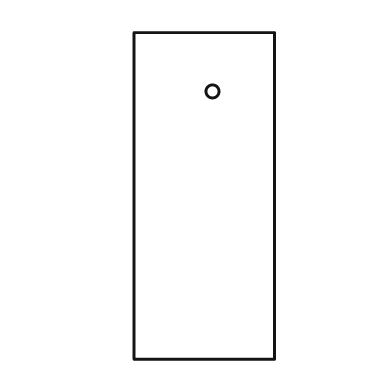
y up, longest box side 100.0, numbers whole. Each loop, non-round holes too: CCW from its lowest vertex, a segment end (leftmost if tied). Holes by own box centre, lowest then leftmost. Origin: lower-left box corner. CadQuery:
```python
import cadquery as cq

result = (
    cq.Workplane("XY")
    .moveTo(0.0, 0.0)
    .lineTo(43.0, 0.0)
    .lineTo(43.0, 100.0)
    .lineTo(0.0, 100.0)
    .close()
    .moveTo(24.0, 82.0)
    .circle(2.0)
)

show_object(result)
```